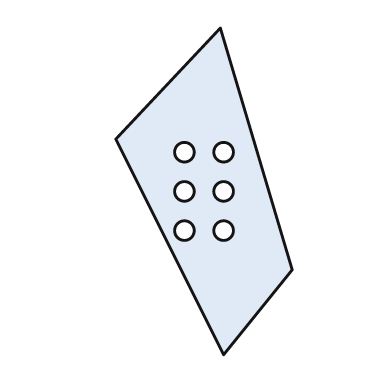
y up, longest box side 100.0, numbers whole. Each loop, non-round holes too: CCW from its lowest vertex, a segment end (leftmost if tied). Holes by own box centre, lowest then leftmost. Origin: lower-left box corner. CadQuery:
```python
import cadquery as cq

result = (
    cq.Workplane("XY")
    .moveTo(33.0, 0.0)
    .lineTo(54.0, 26.0)
    .lineTo(32.0, 100.0)
    .lineTo(0.0, 66.0)
    .close()
    .moveTo(21.0, 38.0)
    .circle(3.0)
    .moveTo(33.0, 38.0)
    .circle(3.0)
    .moveTo(21.0, 50.0)
    .circle(3.0)
    .moveTo(33.0, 50.0)
    .circle(3.0)
    .moveTo(21.0, 62.0)
    .circle(3.0)
    .moveTo(33.0, 62.0)
    .circle(3.0)
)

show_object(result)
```